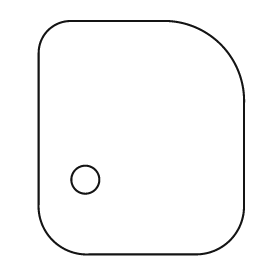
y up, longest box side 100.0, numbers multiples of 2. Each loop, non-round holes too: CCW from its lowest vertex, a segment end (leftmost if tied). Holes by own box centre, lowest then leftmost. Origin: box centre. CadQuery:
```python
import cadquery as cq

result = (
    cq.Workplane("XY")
    .moveTo(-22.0, -50.0)
    .lineTo(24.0, -50.0)
    .threePointArc((38.0, -44.0), (44.0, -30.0))
    .lineTo(44.0, 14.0)
    .threePointArc((34.0, 40.0), (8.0, 50.0))
    .lineTo(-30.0, 50.0)
    .threePointArc((-40.0, 46.0), (-44.0, 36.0))
    .lineTo(-44.0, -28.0)
    .threePointArc((-38.0, -44.0), (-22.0, -50.0))
    .close()
    .moveTo(-24.0, -18.0)
    .circle(6.0)
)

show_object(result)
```